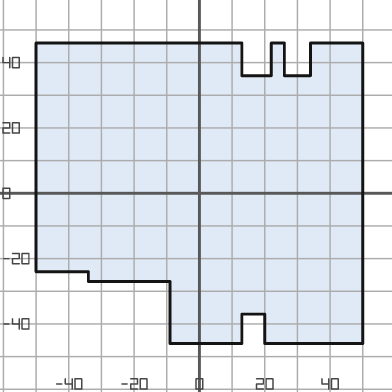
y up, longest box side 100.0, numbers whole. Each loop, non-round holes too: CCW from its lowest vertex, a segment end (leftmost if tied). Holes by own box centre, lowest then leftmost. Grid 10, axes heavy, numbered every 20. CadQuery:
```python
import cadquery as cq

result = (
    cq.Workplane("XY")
    .moveTo(-9.0, -46.0)
    .lineTo(13.0, -46.0)
    .lineTo(13.0, -37.0)
    .lineTo(20.0, -37.0)
    .lineTo(20.0, -46.0)
    .lineTo(50.0, -46.0)
    .lineTo(50.0, 46.0)
    .lineTo(34.0, 46.0)
    .lineTo(34.0, 36.0)
    .lineTo(26.0, 36.0)
    .lineTo(26.0, 46.0)
    .lineTo(22.0, 46.0)
    .lineTo(22.0, 36.0)
    .lineTo(13.0, 36.0)
    .lineTo(13.0, 46.0)
    .lineTo(-50.0, 46.0)
    .lineTo(-50.0, -24.0)
    .lineTo(-34.0, -24.0)
    .lineTo(-34.0, -27.0)
    .lineTo(-9.0, -27.0)
    .close()
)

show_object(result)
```